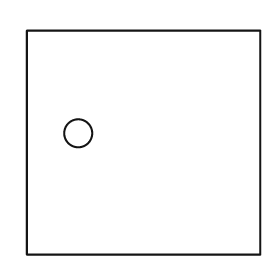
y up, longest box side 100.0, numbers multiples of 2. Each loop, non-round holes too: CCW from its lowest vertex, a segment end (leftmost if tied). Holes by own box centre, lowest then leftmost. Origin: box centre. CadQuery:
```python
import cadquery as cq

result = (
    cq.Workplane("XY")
    .moveTo(-50.0, -48.0)
    .lineTo(50.0, -48.0)
    .lineTo(50.0, 48.0)
    .lineTo(-50.0, 48.0)
    .close()
    .moveTo(-28.0, 4.0)
    .circle(6.0)
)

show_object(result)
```